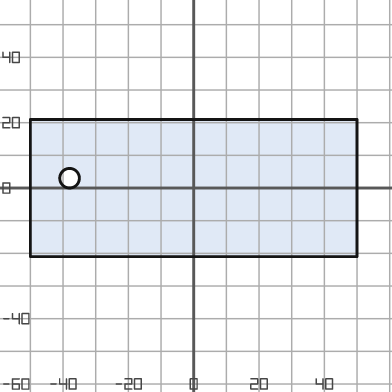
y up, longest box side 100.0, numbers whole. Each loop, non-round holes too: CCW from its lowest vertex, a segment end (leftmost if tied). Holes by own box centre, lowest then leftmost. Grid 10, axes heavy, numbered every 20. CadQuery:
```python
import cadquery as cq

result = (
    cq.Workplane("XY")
    .moveTo(-50.0, -21.0)
    .lineTo(50.0, -21.0)
    .lineTo(50.0, 21.0)
    .lineTo(-50.0, 21.0)
    .close()
    .moveTo(-38.0, 3.0)
    .circle(3.0)
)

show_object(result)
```